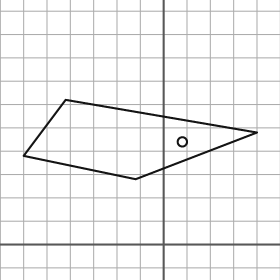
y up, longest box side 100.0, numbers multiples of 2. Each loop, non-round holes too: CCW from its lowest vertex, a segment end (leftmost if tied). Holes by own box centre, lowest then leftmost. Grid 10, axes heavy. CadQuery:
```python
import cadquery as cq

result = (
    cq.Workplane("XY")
    .moveTo(-12.0, 28.0)
    .lineTo(40.0, 48.0)
    .lineTo(-42.0, 62.0)
    .lineTo(-60.0, 38.0)
    .close()
    .moveTo(8.0, 44.0)
    .circle(2.0)
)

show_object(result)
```